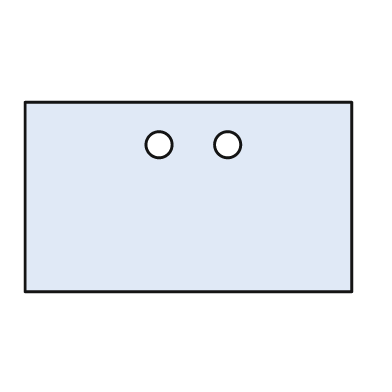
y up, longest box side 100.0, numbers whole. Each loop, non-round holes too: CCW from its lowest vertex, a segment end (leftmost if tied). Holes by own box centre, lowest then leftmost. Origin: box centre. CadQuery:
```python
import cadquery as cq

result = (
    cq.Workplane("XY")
    .moveTo(-50.0, -29.0)
    .lineTo(50.0, -29.0)
    .lineTo(50.0, 29.0)
    .lineTo(-50.0, 29.0)
    .close()
    .moveTo(-9.0, 16.0)
    .circle(4.0)
    .moveTo(12.0, 16.0)
    .circle(4.0)
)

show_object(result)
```